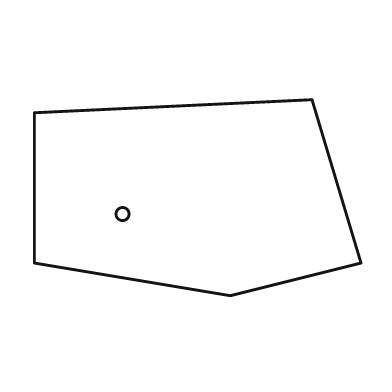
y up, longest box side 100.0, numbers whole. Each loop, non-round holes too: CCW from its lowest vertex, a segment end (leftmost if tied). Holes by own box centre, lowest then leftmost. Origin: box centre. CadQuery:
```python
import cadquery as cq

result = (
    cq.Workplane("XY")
    .moveTo(10.0, -30.0)
    .lineTo(50.0, -20.0)
    .lineTo(35.0, 30.0)
    .lineTo(-50.0, 26.0)
    .lineTo(-50.0, -20.0)
    .close()
    .moveTo(-23.0, -5.0)
    .circle(2.0)
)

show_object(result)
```